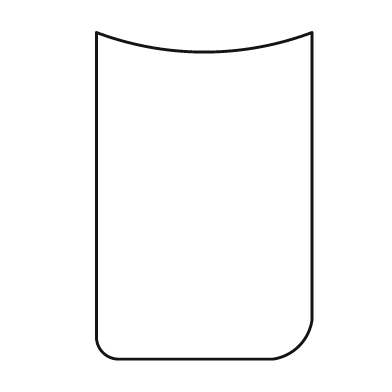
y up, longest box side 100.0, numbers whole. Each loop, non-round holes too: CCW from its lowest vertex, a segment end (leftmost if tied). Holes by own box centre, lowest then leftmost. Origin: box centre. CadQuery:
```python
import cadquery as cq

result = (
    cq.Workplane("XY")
    .moveTo(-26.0, -50.0)
    .lineTo(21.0, -50.0)
    .threePointArc((29.0, -46.0), (33.0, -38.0))
    .lineTo(33.0, 50.0)
    .threePointArc((0.0, 44.0), (-33.0, 50.0))
    .lineTo(-33.0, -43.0)
    .threePointArc((-31.0, -48.0), (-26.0, -50.0))
    .close()
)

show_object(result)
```